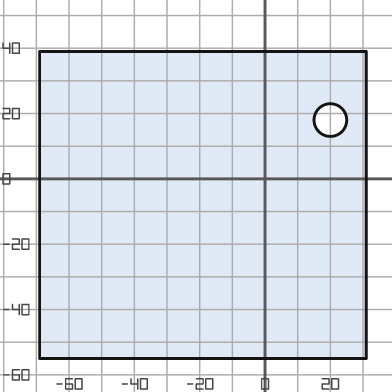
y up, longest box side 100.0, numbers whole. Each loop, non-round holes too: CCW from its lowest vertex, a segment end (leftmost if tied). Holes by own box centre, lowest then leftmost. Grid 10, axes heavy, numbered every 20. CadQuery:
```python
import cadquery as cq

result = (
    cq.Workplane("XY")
    .moveTo(-69.0, -55.0)
    .lineTo(31.0, -55.0)
    .lineTo(31.0, 39.0)
    .lineTo(-69.0, 39.0)
    .close()
    .moveTo(20.0, 18.0)
    .circle(5.0)
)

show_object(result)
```